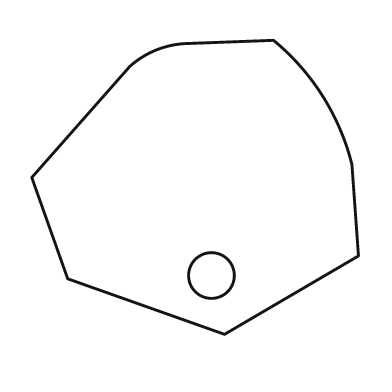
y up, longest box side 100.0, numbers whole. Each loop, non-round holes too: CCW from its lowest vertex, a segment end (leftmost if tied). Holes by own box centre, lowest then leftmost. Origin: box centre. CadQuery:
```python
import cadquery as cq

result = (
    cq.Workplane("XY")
    .moveTo(9.0, -45.0)
    .lineTo(50.0, -21.0)
    .lineTo(48.0, 7.0)
    .threePointArc((39.0, 28.0), (24.0, 45.0))
    .lineTo(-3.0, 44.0)
    .threePointArc((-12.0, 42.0), (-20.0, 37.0))
    .lineTo(-50.0, 3.0)
    .lineTo(-39.0, -28.0)
    .close()
    .moveTo(5.0, -27.0)
    .circle(7.0)
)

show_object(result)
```